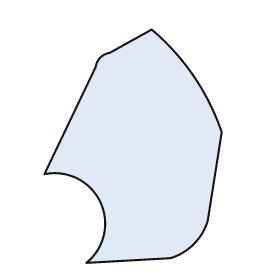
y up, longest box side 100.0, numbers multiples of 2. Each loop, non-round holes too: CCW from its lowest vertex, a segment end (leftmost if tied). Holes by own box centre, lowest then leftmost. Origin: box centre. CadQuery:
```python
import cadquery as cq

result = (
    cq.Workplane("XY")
    .moveTo(-20.0, -50.0)
    .lineTo(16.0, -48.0)
    .threePointArc((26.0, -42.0), (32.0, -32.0))
    .lineTo(38.0, 6.0)
    .threePointArc((26.0, 30.0), (8.0, 50.0))
    .lineTo(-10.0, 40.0)
    .threePointArc((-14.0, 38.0), (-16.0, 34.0))
    .lineTo(-38.0, -12.0)
    .threePointArc((-14.0, -24.0), (-20.0, -50.0))
    .close()
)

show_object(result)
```